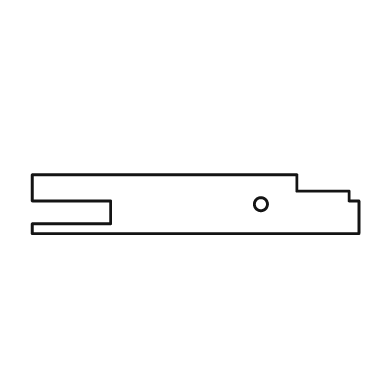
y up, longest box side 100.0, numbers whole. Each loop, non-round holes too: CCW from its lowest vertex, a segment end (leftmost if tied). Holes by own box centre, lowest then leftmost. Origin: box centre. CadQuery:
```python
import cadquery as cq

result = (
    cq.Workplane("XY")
    .moveTo(-50.0, -9.0)
    .lineTo(50.0, -9.0)
    .lineTo(50.0, 1.0)
    .lineTo(47.0, 1.0)
    .lineTo(47.0, 4.0)
    .lineTo(31.0, 4.0)
    .lineTo(31.0, 9.0)
    .lineTo(-50.0, 9.0)
    .lineTo(-50.0, 1.0)
    .lineTo(-26.0, 1.0)
    .lineTo(-26.0, -6.0)
    .lineTo(-50.0, -6.0)
    .close()
    .moveTo(20.0, 0.0)
    .circle(2.0)
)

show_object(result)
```